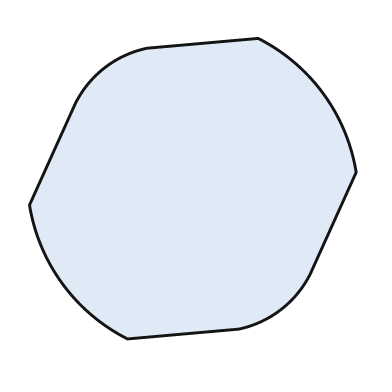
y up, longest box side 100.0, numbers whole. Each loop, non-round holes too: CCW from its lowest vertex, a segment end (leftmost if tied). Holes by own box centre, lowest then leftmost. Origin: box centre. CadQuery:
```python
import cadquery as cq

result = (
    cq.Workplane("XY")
    .moveTo(-20.0, -46.0)
    .lineTo(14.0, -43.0)
    .threePointArc((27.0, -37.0), (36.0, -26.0))
    .lineTo(50.0, 5.0)
    .threePointArc((40.0, 29.0), (20.0, 46.0))
    .lineTo(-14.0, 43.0)
    .threePointArc((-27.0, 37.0), (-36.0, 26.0))
    .lineTo(-50.0, -5.0)
    .threePointArc((-40.0, -29.0), (-20.0, -46.0))
    .close()
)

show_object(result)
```